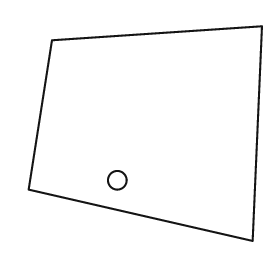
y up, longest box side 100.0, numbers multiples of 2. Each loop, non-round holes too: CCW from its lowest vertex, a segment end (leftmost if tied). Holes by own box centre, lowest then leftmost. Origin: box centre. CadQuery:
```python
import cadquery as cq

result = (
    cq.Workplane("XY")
    .moveTo(46.0, -46.0)
    .lineTo(50.0, 46.0)
    .lineTo(-40.0, 40.0)
    .lineTo(-50.0, -24.0)
    .close()
    .moveTo(-12.0, -20.0)
    .circle(4.0)
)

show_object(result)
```